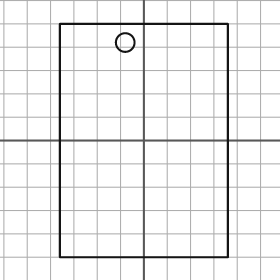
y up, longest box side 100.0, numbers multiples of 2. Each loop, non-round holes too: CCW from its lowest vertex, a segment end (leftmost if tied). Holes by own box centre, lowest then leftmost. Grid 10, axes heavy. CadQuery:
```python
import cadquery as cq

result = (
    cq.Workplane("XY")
    .moveTo(-36.0, -50.0)
    .lineTo(36.0, -50.0)
    .lineTo(36.0, 50.0)
    .lineTo(-36.0, 50.0)
    .close()
    .moveTo(-8.0, 42.0)
    .circle(4.0)
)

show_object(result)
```